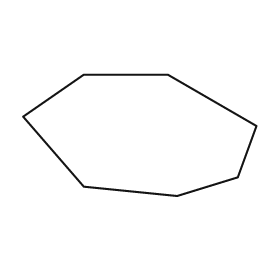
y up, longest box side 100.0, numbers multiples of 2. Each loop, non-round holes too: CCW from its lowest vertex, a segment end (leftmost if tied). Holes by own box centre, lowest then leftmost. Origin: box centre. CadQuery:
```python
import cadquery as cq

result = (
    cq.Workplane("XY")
    .moveTo(16.0, -26.0)
    .lineTo(42.0, -18.0)
    .lineTo(50.0, 4.0)
    .lineTo(12.0, 26.0)
    .lineTo(-24.0, 26.0)
    .lineTo(-50.0, 8.0)
    .lineTo(-24.0, -22.0)
    .close()
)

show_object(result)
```